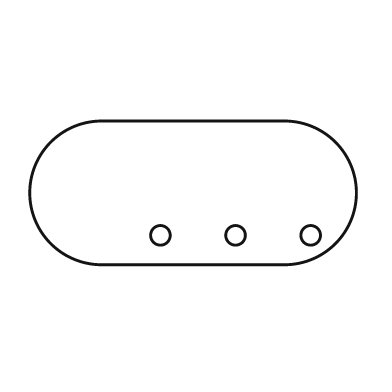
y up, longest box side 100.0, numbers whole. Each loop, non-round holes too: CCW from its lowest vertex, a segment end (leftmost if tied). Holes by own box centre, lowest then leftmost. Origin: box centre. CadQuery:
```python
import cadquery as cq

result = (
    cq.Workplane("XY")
    .moveTo(-28.0, -22.0)
    .lineTo(28.0, -22.0)
    .threePointArc((50.0, 0.0), (28.0, 22.0))
    .lineTo(-28.0, 22.0)
    .threePointArc((-50.0, 0.0), (-28.0, -22.0))
    .close()
    .moveTo(-10.0, -13.0)
    .circle(3.0)
    .moveTo(13.0, -13.0)
    .circle(3.0)
    .moveTo(36.0, -13.0)
    .circle(3.0)
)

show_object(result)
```